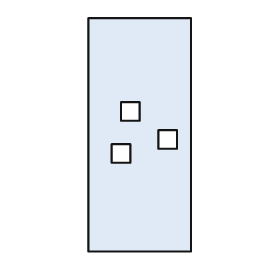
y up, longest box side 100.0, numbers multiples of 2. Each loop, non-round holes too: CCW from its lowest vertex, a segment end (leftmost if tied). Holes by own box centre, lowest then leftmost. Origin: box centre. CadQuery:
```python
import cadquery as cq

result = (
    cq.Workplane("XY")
    .moveTo(-22.0, -50.0)
    .lineTo(22.0, -50.0)
    .lineTo(22.0, 50.0)
    .lineTo(-22.0, 50.0)
    .close()
    .moveTo(-12.0, -12.0)
    .lineTo(-4.0, -12.0)
    .lineTo(-4.0, -4.0)
    .lineTo(-12.0, -4.0)
    .close()
    .moveTo(8.0, -6.0)
    .lineTo(16.0, -6.0)
    .lineTo(16.0, 2.0)
    .lineTo(8.0, 2.0)
    .close()
    .moveTo(-8.0, 6.0)
    .lineTo(0.0, 6.0)
    .lineTo(0.0, 14.0)
    .lineTo(-8.0, 14.0)
    .close()
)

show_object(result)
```